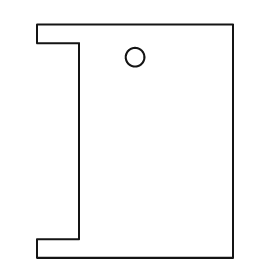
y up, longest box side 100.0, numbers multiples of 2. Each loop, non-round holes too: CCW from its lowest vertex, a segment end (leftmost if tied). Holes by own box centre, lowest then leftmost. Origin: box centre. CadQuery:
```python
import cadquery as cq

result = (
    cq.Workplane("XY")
    .moveTo(-42.0, -50.0)
    .lineTo(42.0, -50.0)
    .lineTo(42.0, 50.0)
    .lineTo(-42.0, 50.0)
    .lineTo(-42.0, 42.0)
    .lineTo(-24.0, 42.0)
    .lineTo(-24.0, -42.0)
    .lineTo(-42.0, -42.0)
    .close()
    .moveTo(0.0, 36.0)
    .circle(4.0)
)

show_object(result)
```